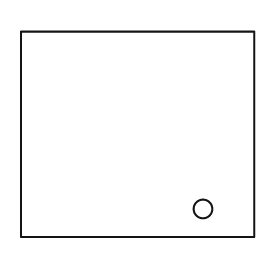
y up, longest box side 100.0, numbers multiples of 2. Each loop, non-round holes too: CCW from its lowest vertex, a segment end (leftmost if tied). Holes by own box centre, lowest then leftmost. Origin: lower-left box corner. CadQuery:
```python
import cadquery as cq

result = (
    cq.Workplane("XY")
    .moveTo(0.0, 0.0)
    .lineTo(100.0, 0.0)
    .lineTo(100.0, 88.0)
    .lineTo(0.0, 88.0)
    .close()
    .moveTo(78.0, 12.0)
    .circle(4.0)
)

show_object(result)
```